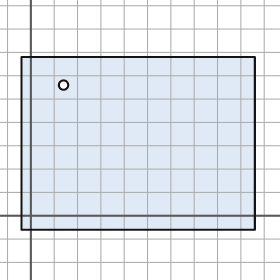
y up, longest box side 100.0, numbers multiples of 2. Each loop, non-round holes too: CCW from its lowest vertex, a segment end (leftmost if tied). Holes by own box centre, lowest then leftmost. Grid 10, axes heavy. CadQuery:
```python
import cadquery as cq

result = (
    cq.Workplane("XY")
    .moveTo(-4.0, -6.0)
    .lineTo(96.0, -6.0)
    .lineTo(96.0, 68.0)
    .lineTo(-4.0, 68.0)
    .close()
    .moveTo(14.0, 56.0)
    .circle(2.0)
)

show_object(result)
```